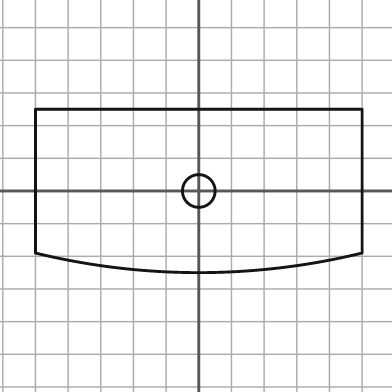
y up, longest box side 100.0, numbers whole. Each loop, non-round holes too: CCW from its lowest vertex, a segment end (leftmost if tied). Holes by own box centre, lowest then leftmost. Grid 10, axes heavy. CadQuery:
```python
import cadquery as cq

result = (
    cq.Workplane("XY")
    .moveTo(-50.0, -19.0)
    .threePointArc((0.0, -25.0), (50.0, -19.0))
    .lineTo(50.0, 25.0)
    .lineTo(-50.0, 25.0)
    .close()
    .moveTo(0.0, 0.0)
    .circle(5.0)
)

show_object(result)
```